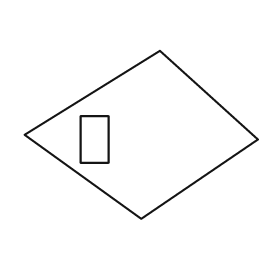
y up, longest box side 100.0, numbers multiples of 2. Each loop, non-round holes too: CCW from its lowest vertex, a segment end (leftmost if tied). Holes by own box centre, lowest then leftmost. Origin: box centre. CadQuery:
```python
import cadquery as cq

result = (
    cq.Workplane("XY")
    .moveTo(0.0, -36.0)
    .lineTo(50.0, -2.0)
    .lineTo(8.0, 36.0)
    .lineTo(-50.0, 0.0)
    .close()
    .moveTo(-26.0, -12.0)
    .lineTo(-14.0, -12.0)
    .lineTo(-14.0, 8.0)
    .lineTo(-26.0, 8.0)
    .close()
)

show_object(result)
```